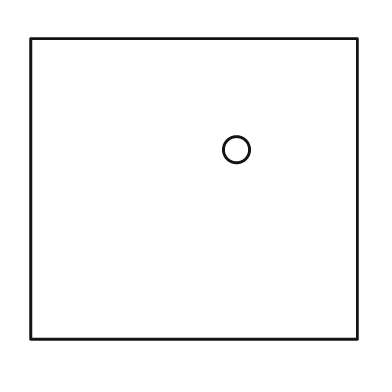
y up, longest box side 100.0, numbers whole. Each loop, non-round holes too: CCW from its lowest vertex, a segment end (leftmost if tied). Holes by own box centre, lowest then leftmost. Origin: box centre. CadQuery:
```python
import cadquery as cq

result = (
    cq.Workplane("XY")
    .moveTo(-50.0, -46.0)
    .lineTo(50.0, -46.0)
    .lineTo(50.0, 46.0)
    .lineTo(-50.0, 46.0)
    .close()
    .moveTo(13.0, 12.0)
    .circle(4.0)
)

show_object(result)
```